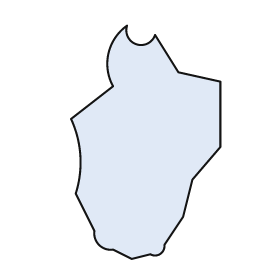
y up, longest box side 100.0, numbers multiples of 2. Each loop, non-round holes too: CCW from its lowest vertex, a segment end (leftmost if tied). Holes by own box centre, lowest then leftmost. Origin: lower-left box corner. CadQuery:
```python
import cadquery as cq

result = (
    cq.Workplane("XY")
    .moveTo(26.0, 0.0)
    .lineTo(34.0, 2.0)
    .threePointArc((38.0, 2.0), (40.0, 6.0))
    .lineTo(48.0, 18.0)
    .lineTo(52.0, 34.0)
    .lineTo(64.0, 48.0)
    .lineTo(64.0, 76.0)
    .lineTo(46.0, 80.0)
    .lineTo(36.0, 96.0)
    .threePointArc((28.0, 92.0), (24.0, 100.0))
    .threePointArc((16.0, 88.0), (18.0, 74.0))
    .lineTo(0.0, 60.0)
    .threePointArc((4.0, 44.0), (2.0, 28.0))
    .lineTo(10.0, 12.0)
    .threePointArc((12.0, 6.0), (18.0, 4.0))
    .close()
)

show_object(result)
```